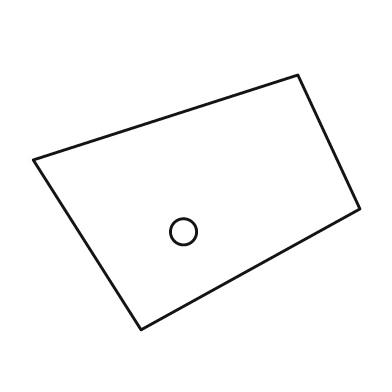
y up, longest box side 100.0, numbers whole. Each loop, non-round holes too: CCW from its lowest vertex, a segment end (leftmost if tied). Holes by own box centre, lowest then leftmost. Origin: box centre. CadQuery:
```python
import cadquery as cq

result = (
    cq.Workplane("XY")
    .moveTo(-17.0, -39.0)
    .lineTo(50.0, -2.0)
    .lineTo(31.0, 39.0)
    .lineTo(-50.0, 13.0)
    .close()
    .moveTo(-4.0, -9.0)
    .circle(4.0)
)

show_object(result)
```